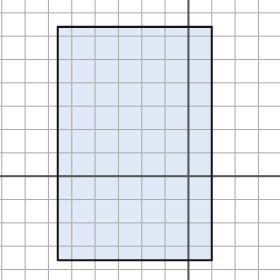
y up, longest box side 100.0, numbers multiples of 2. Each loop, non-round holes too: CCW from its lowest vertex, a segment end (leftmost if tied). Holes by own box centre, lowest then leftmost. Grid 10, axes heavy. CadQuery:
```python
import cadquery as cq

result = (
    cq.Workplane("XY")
    .moveTo(-56.0, -36.0)
    .lineTo(10.0, -36.0)
    .lineTo(10.0, 64.0)
    .lineTo(-56.0, 64.0)
    .close()
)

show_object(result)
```